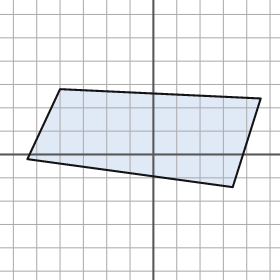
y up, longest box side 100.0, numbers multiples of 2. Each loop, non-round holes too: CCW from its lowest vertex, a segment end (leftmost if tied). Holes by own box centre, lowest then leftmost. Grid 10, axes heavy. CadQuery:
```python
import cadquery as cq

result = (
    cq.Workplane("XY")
    .moveTo(34.0, -14.0)
    .lineTo(46.0, 24.0)
    .lineTo(-40.0, 28.0)
    .lineTo(-54.0, -2.0)
    .close()
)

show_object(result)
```